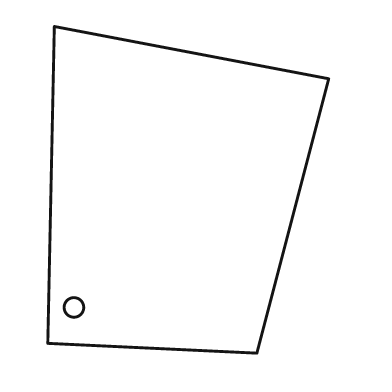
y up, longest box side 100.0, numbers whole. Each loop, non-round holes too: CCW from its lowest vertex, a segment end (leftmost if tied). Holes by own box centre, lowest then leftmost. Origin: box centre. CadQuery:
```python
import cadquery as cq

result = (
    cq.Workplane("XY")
    .moveTo(21.0, -50.0)
    .lineTo(43.0, 34.0)
    .lineTo(-41.0, 50.0)
    .lineTo(-43.0, -47.0)
    .close()
    .moveTo(-35.0, -36.0)
    .circle(3.0)
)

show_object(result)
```